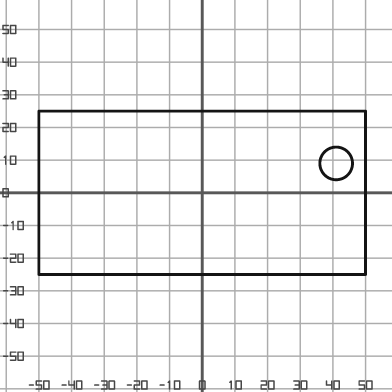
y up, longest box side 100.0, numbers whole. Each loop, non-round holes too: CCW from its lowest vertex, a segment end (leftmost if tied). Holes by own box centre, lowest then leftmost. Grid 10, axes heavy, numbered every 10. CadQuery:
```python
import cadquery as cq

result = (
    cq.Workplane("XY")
    .moveTo(-50.0, -25.0)
    .lineTo(50.0, -25.0)
    .lineTo(50.0, 25.0)
    .lineTo(-50.0, 25.0)
    .close()
    .moveTo(41.0, 9.0)
    .circle(5.0)
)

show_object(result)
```